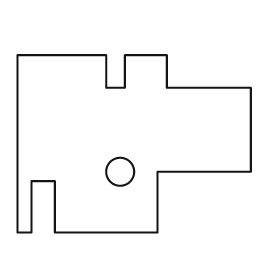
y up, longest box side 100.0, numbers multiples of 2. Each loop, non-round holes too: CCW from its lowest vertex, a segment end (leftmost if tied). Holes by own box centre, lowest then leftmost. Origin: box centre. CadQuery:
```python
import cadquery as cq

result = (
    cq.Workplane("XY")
    .moveTo(-50.0, -38.0)
    .lineTo(-44.0, -38.0)
    .lineTo(-44.0, -16.0)
    .lineTo(-34.0, -16.0)
    .lineTo(-34.0, -38.0)
    .lineTo(10.0, -38.0)
    .lineTo(10.0, -12.0)
    .lineTo(50.0, -12.0)
    .lineTo(50.0, 24.0)
    .lineTo(14.0, 24.0)
    .lineTo(14.0, 38.0)
    .lineTo(-4.0, 38.0)
    .lineTo(-4.0, 24.0)
    .lineTo(-12.0, 24.0)
    .lineTo(-12.0, 38.0)
    .lineTo(-50.0, 38.0)
    .close()
    .moveTo(-6.0, -12.0)
    .circle(6.0)
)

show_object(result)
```